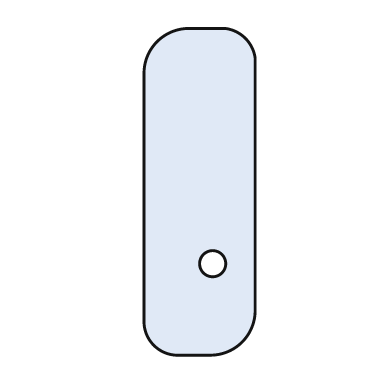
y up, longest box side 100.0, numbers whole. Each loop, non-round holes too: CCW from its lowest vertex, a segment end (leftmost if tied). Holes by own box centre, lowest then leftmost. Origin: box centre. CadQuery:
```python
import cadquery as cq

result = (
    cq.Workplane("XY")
    .moveTo(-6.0, -50.0)
    .lineTo(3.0, -50.0)
    .threePointArc((13.0, -46.0), (17.0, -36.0))
    .lineTo(17.0, 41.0)
    .threePointArc((14.0, 47.0), (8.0, 50.0))
    .lineTo(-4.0, 50.0)
    .threePointArc((-13.0, 46.0), (-17.0, 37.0))
    .lineTo(-17.0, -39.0)
    .threePointArc((-14.0, -47.0), (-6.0, -50.0))
    .close()
    .moveTo(4.0, -22.0)
    .circle(4.0)
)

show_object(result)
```